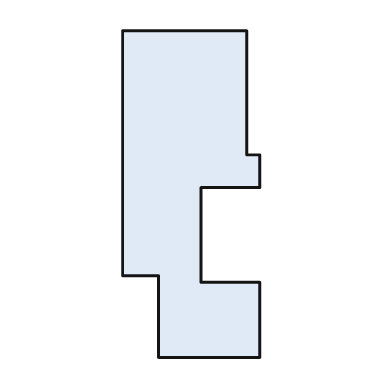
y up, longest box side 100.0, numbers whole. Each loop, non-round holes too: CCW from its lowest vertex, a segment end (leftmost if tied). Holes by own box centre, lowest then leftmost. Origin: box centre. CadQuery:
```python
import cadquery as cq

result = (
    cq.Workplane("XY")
    .moveTo(-10.0, -50.0)
    .lineTo(21.0, -50.0)
    .lineTo(21.0, -27.0)
    .lineTo(3.0, -27.0)
    .lineTo(3.0, 2.0)
    .lineTo(21.0, 2.0)
    .lineTo(21.0, 12.0)
    .lineTo(17.0, 12.0)
    .lineTo(17.0, 50.0)
    .lineTo(-21.0, 50.0)
    .lineTo(-21.0, -25.0)
    .lineTo(-10.0, -25.0)
    .close()
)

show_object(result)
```